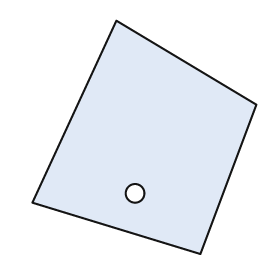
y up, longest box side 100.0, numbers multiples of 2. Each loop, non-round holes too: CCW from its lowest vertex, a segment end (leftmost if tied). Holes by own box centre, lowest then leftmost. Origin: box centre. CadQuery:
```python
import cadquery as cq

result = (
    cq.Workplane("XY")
    .moveTo(24.0, -50.0)
    .lineTo(48.0, 14.0)
    .lineTo(-12.0, 50.0)
    .lineTo(-48.0, -28.0)
    .close()
    .moveTo(-4.0, -24.0)
    .circle(4.0)
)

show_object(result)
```